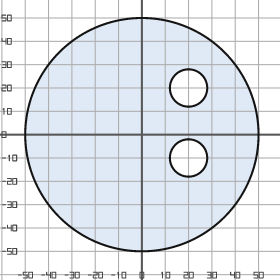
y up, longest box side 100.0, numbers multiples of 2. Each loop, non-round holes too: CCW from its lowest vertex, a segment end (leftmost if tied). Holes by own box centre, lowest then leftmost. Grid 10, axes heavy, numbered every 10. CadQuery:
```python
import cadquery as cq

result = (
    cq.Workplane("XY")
    .moveTo(0.0, 0.0)
    .circle(50.0)
    .moveTo(20.0, -10.0)
    .circle(8.0)
    .moveTo(20.0, 20.0)
    .circle(8.0)
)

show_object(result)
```